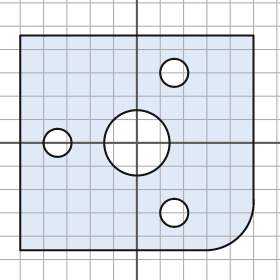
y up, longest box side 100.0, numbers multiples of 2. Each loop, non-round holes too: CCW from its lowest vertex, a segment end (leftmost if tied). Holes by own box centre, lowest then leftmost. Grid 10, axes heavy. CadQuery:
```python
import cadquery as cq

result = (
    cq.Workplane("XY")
    .moveTo(-50.0, -46.0)
    .lineTo(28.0, -46.0)
    .threePointArc((44.0, -40.0), (50.0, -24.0))
    .lineTo(50.0, 46.0)
    .lineTo(-50.0, 46.0)
    .close()
    .moveTo(16.0, -30.0)
    .circle(6.0)
    .moveTo(-34.0, 0.0)
    .circle(6.0)
    .moveTo(0.0, 0.0)
    .circle(14.0)
    .moveTo(16.0, 30.0)
    .circle(6.0)
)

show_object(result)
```